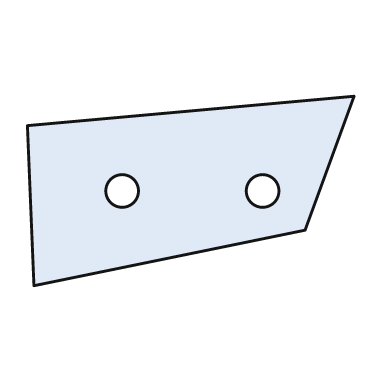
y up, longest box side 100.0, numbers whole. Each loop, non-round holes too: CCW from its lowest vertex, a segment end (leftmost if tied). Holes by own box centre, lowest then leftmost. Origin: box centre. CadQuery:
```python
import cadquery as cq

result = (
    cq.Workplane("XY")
    .moveTo(-48.0, -29.0)
    .lineTo(35.0, -12.0)
    .lineTo(50.0, 29.0)
    .lineTo(-50.0, 20.0)
    .close()
    .moveTo(-21.0, 0.0)
    .circle(5.0)
    .moveTo(22.0, 0.0)
    .circle(5.0)
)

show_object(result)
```